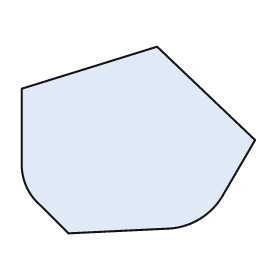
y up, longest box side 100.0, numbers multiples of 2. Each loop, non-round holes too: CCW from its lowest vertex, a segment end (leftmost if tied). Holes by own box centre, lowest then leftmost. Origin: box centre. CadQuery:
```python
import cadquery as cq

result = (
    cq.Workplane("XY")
    .moveTo(-30.0, -40.0)
    .lineTo(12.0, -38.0)
    .threePointArc((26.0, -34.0), (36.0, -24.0))
    .lineTo(50.0, 0.0)
    .lineTo(8.0, 40.0)
    .lineTo(-50.0, 22.0)
    .lineTo(-50.0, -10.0)
    .threePointArc((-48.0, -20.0), (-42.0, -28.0))
    .close()
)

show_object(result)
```